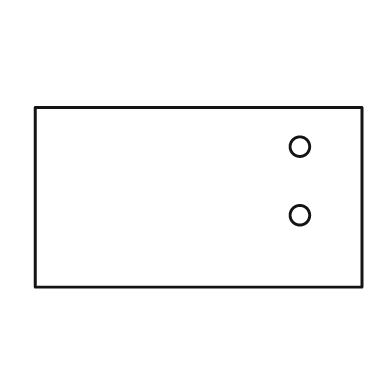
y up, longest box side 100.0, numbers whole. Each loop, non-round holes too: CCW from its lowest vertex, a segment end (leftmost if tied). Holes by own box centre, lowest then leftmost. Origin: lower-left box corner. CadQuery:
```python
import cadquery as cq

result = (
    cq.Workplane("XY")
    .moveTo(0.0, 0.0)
    .lineTo(100.0, 0.0)
    .lineTo(100.0, 55.0)
    .lineTo(0.0, 55.0)
    .close()
    .moveTo(81.0, 22.0)
    .circle(3.0)
    .moveTo(81.0, 43.0)
    .circle(3.0)
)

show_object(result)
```